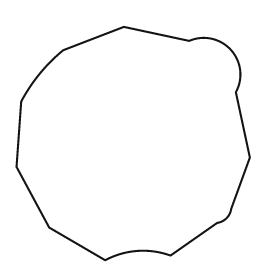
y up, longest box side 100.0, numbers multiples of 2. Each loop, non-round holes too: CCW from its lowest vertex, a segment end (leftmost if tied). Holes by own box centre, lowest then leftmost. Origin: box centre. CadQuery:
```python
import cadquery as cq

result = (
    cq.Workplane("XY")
    .moveTo(-12.0, -50.0)
    .threePointArc((2.0, -46.0), (16.0, -48.0))
    .lineTo(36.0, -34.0)
    .threePointArc((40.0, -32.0), (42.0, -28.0))
    .lineTo(50.0, -6.0)
    .lineTo(44.0, 22.0)
    .threePointArc((42.0, 40.0), (24.0, 44.0))
    .lineTo(-4.0, 50.0)
    .lineTo(-30.0, 40.0)
    .threePointArc((-40.0, 30.0), (-48.0, 18.0))
    .lineTo(-50.0, -10.0)
    .lineTo(-36.0, -36.0)
    .close()
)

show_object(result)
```